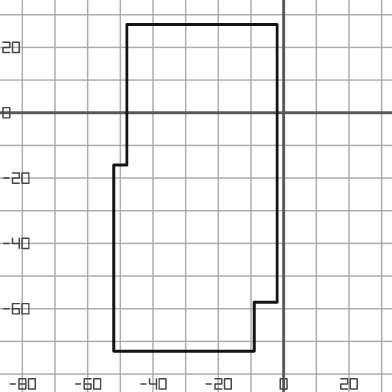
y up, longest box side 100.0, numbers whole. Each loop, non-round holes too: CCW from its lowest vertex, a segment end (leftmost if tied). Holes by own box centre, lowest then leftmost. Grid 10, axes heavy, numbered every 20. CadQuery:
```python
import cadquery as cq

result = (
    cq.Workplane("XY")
    .moveTo(-52.0, -73.0)
    .lineTo(-9.0, -73.0)
    .lineTo(-9.0, -58.0)
    .lineTo(-2.0, -58.0)
    .lineTo(-2.0, 27.0)
    .lineTo(-48.0, 27.0)
    .lineTo(-48.0, -16.0)
    .lineTo(-52.0, -16.0)
    .close()
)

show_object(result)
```